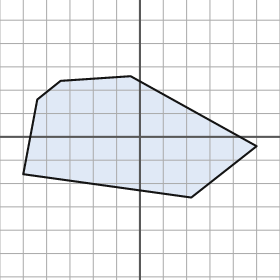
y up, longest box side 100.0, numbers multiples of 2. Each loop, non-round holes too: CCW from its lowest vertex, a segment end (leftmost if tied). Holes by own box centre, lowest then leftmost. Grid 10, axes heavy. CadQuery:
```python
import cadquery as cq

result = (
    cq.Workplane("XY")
    .moveTo(22.0, -26.0)
    .lineTo(50.0, -4.0)
    .lineTo(-4.0, 26.0)
    .lineTo(-34.0, 24.0)
    .lineTo(-44.0, 16.0)
    .lineTo(-50.0, -16.0)
    .close()
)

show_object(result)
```